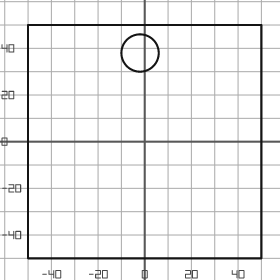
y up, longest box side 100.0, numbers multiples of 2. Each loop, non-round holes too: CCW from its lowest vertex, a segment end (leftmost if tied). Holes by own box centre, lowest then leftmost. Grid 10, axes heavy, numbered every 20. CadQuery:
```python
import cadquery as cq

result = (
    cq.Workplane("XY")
    .moveTo(-50.0, -50.0)
    .lineTo(50.0, -50.0)
    .lineTo(50.0, 50.0)
    .lineTo(-50.0, 50.0)
    .close()
    .moveTo(-2.0, 38.0)
    .circle(8.0)
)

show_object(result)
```